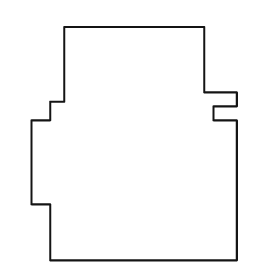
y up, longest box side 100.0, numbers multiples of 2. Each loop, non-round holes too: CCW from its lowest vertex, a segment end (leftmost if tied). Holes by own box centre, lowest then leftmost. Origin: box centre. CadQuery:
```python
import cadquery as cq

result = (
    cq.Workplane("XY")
    .moveTo(-36.0, -50.0)
    .lineTo(44.0, -50.0)
    .lineTo(44.0, 10.0)
    .lineTo(34.0, 10.0)
    .lineTo(34.0, 16.0)
    .lineTo(44.0, 16.0)
    .lineTo(44.0, 22.0)
    .lineTo(30.0, 22.0)
    .lineTo(30.0, 50.0)
    .lineTo(-30.0, 50.0)
    .lineTo(-30.0, 18.0)
    .lineTo(-36.0, 18.0)
    .lineTo(-36.0, 10.0)
    .lineTo(-44.0, 10.0)
    .lineTo(-44.0, -26.0)
    .lineTo(-36.0, -26.0)
    .close()
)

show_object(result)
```